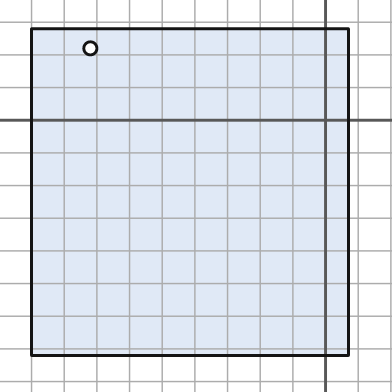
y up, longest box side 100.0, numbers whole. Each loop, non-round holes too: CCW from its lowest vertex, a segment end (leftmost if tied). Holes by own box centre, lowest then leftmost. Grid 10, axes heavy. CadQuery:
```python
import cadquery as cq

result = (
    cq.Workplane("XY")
    .moveTo(-90.0, -72.0)
    .lineTo(7.0, -72.0)
    .lineTo(7.0, 28.0)
    .lineTo(-90.0, 28.0)
    .close()
    .moveTo(-72.0, 22.0)
    .circle(2.0)
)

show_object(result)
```